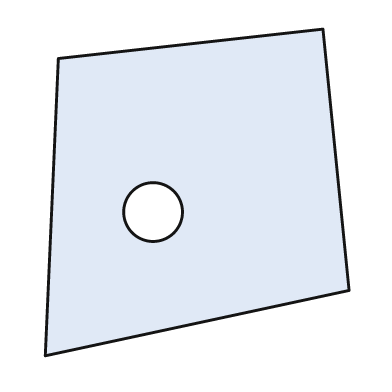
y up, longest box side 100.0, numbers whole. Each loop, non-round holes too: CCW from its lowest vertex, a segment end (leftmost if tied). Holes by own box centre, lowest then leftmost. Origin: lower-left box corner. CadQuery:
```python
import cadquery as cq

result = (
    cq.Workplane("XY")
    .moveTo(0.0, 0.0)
    .lineTo(93.0, 20.0)
    .lineTo(85.0, 100.0)
    .lineTo(4.0, 91.0)
    .close()
    .moveTo(33.0, 44.0)
    .circle(9.0)
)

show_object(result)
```